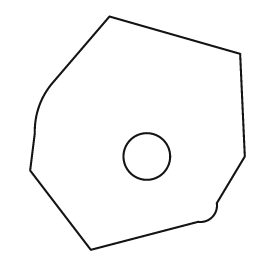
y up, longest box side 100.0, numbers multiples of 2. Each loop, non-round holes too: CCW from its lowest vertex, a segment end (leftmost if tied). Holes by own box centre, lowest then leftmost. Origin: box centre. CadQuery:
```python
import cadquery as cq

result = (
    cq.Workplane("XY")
    .moveTo(-20.0, -50.0)
    .lineTo(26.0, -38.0)
    .threePointArc((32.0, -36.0), (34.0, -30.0))
    .lineTo(46.0, -10.0)
    .lineTo(44.0, 34.0)
    .lineTo(-12.0, 50.0)
    .lineTo(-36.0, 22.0)
    .threePointArc((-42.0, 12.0), (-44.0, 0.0))
    .lineTo(-46.0, -16.0)
    .close()
    .moveTo(4.0, -10.0)
    .circle(10.0)
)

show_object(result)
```